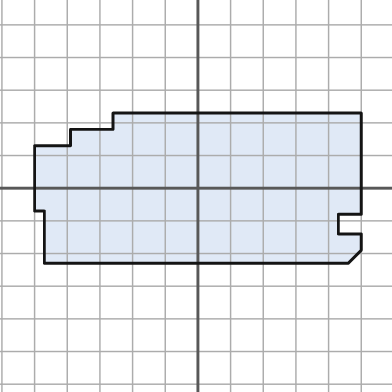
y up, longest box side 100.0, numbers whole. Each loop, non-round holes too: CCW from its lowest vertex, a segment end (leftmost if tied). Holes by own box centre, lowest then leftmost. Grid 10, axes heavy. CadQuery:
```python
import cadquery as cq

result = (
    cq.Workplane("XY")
    .moveTo(-47.0, -23.0)
    .lineTo(46.0, -23.0)
    .lineTo(50.0, -19.0)
    .lineTo(50.0, -14.0)
    .lineTo(43.0, -14.0)
    .lineTo(43.0, -8.0)
    .lineTo(50.0, -8.0)
    .lineTo(50.0, 23.0)
    .lineTo(-26.0, 23.0)
    .lineTo(-26.0, 18.0)
    .lineTo(-39.0, 18.0)
    .lineTo(-39.0, 13.0)
    .lineTo(-50.0, 13.0)
    .lineTo(-50.0, -7.0)
    .lineTo(-47.0, -7.0)
    .close()
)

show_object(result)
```